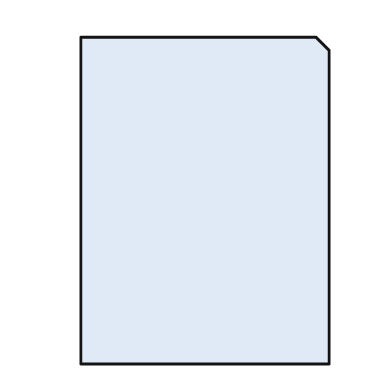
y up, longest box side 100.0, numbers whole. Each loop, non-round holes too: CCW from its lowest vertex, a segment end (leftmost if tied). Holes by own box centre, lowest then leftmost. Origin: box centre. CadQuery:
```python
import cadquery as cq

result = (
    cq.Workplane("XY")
    .moveTo(-38.0, -50.0)
    .lineTo(38.0, -50.0)
    .lineTo(38.0, 46.0)
    .lineTo(34.0, 50.0)
    .lineTo(-38.0, 50.0)
    .close()
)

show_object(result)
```